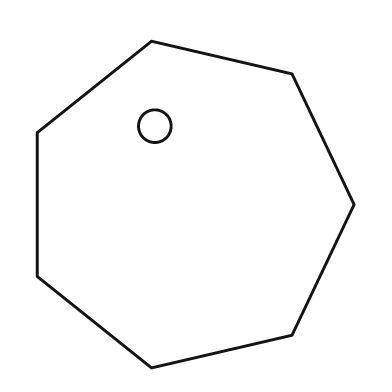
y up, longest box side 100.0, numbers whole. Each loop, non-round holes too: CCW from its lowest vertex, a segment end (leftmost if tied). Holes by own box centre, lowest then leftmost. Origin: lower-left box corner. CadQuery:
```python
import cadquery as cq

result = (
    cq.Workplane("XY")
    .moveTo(35.0, 0.0)
    .lineTo(78.0, 10.0)
    .lineTo(97.0, 50.0)
    .lineTo(78.0, 90.0)
    .lineTo(35.0, 100.0)
    .lineTo(0.0, 72.0)
    .lineTo(0.0, 28.0)
    .close()
    .moveTo(36.0, 74.0)
    .circle(5.0)
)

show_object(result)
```